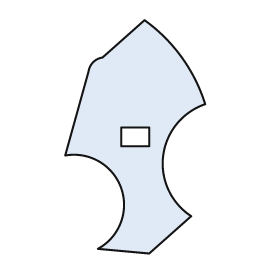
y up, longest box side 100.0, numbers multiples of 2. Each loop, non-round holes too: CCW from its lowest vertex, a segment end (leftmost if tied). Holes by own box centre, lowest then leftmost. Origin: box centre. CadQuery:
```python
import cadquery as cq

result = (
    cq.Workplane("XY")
    .moveTo(6.0, -50.0)
    .lineTo(24.0, -34.0)
    .threePointArc((12.0, -8.0), (30.0, 14.0))
    .threePointArc((20.0, 34.0), (4.0, 50.0))
    .lineTo(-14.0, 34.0)
    .threePointArc((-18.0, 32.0), (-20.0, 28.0))
    .lineTo(-30.0, -8.0)
    .threePointArc((-6.0, -22.0), (-16.0, -48.0))
    .close()
    .moveTo(-6.0, -4.0)
    .lineTo(6.0, -4.0)
    .lineTo(6.0, 4.0)
    .lineTo(-6.0, 4.0)
    .close()
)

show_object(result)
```